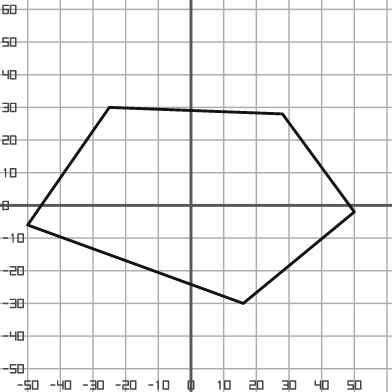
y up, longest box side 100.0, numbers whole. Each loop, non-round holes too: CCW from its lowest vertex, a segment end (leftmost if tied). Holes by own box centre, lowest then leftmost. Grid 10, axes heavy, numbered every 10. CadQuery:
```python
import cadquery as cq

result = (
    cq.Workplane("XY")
    .moveTo(16.0, -30.0)
    .lineTo(50.0, -2.0)
    .lineTo(28.0, 28.0)
    .lineTo(-25.0, 30.0)
    .lineTo(-50.0, -6.0)
    .close()
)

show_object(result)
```